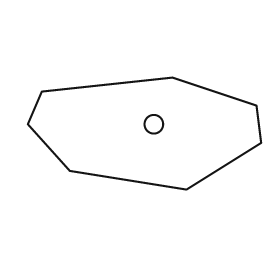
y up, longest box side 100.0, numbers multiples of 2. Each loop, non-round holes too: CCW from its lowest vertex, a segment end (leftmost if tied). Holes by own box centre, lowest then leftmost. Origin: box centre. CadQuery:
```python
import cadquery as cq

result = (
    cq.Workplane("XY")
    .moveTo(18.0, -24.0)
    .lineTo(50.0, -4.0)
    .lineTo(48.0, 12.0)
    .lineTo(12.0, 24.0)
    .lineTo(-44.0, 18.0)
    .lineTo(-50.0, 4.0)
    .lineTo(-32.0, -16.0)
    .close()
    .moveTo(4.0, 4.0)
    .circle(4.0)
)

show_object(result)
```